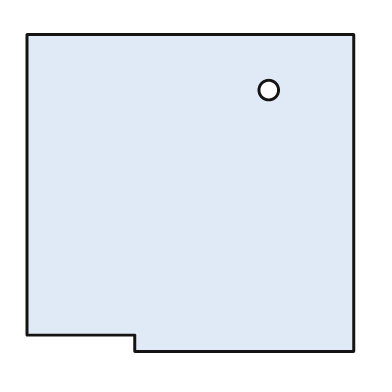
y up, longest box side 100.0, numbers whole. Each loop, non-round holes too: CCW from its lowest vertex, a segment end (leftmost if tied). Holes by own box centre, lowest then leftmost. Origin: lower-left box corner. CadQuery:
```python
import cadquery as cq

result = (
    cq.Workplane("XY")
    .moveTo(33.0, 0.0)
    .lineTo(100.0, 0.0)
    .lineTo(100.0, 97.0)
    .lineTo(0.0, 97.0)
    .lineTo(0.0, 5.0)
    .lineTo(33.0, 5.0)
    .close()
    .moveTo(74.0, 80.0)
    .circle(3.0)
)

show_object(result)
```